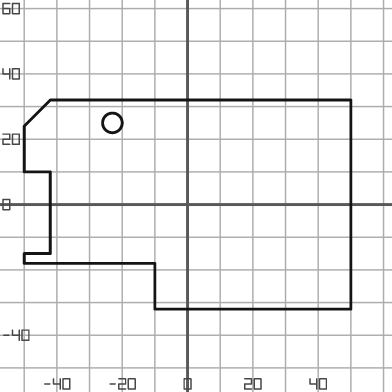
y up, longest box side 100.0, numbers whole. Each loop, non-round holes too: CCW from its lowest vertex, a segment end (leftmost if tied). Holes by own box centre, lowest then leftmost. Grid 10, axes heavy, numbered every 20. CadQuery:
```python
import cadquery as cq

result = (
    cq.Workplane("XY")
    .moveTo(-10.0, -32.0)
    .lineTo(50.0, -32.0)
    .lineTo(50.0, 32.0)
    .lineTo(-42.0, 32.0)
    .lineTo(-50.0, 24.0)
    .lineTo(-50.0, 10.0)
    .lineTo(-42.0, 10.0)
    .lineTo(-42.0, -15.0)
    .lineTo(-50.0, -15.0)
    .lineTo(-50.0, -18.0)
    .lineTo(-10.0, -18.0)
    .close()
    .moveTo(-23.0, 25.0)
    .circle(3.0)
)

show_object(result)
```